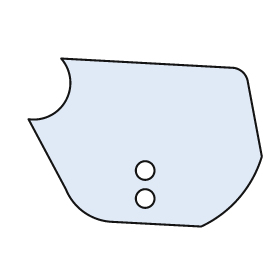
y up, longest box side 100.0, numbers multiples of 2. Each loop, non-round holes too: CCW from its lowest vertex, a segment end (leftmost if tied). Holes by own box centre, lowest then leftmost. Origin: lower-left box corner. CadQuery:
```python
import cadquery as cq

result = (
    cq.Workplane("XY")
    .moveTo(74.0, 0.0)
    .threePointArc((90.0, 12.0), (100.0, 30.0))
    .lineTo(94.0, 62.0)
    .threePointArc((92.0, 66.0), (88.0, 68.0))
    .lineTo(14.0, 72.0)
    .threePointArc((16.0, 54.0), (0.0, 46.0))
    .lineTo(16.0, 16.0)
    .threePointArc((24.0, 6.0), (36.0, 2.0))
    .close()
    .moveTo(50.0, 12.0)
    .circle(4.0)
    .moveTo(50.0, 24.0)
    .circle(4.0)
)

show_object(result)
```